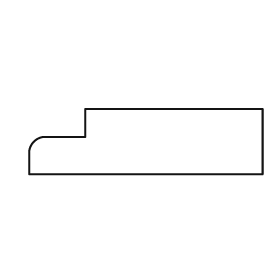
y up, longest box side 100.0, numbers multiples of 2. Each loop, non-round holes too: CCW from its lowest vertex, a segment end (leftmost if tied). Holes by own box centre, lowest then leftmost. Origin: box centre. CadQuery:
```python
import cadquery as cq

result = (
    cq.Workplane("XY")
    .moveTo(-50.0, -14.0)
    .lineTo(50.0, -14.0)
    .lineTo(50.0, 14.0)
    .lineTo(-26.0, 14.0)
    .lineTo(-26.0, 2.0)
    .lineTo(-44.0, 2.0)
    .threePointArc((-48.0, 0.0), (-50.0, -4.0))
    .close()
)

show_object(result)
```